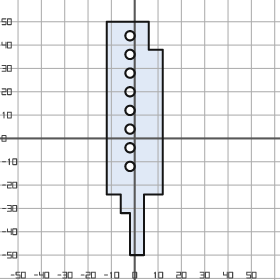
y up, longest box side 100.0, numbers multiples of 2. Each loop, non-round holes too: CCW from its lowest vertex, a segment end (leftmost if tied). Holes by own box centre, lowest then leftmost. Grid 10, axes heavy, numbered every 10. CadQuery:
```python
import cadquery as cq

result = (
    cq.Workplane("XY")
    .moveTo(-2.0, -50.0)
    .lineTo(4.0, -50.0)
    .lineTo(4.0, -24.0)
    .lineTo(12.0, -24.0)
    .lineTo(12.0, 38.0)
    .lineTo(6.0, 38.0)
    .lineTo(6.0, 50.0)
    .lineTo(-12.0, 50.0)
    .lineTo(-12.0, -24.0)
    .lineTo(-6.0, -24.0)
    .lineTo(-6.0, -32.0)
    .lineTo(-2.0, -32.0)
    .close()
    .moveTo(-2.0, -12.0)
    .circle(2.0)
    .moveTo(-2.0, -4.0)
    .circle(2.0)
    .moveTo(-2.0, 4.0)
    .circle(2.0)
    .moveTo(-2.0, 12.0)
    .circle(2.0)
    .moveTo(-2.0, 20.0)
    .circle(2.0)
    .moveTo(-2.0, 28.0)
    .circle(2.0)
    .moveTo(-2.0, 36.0)
    .circle(2.0)
    .moveTo(-2.0, 44.0)
    .circle(2.0)
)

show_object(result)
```